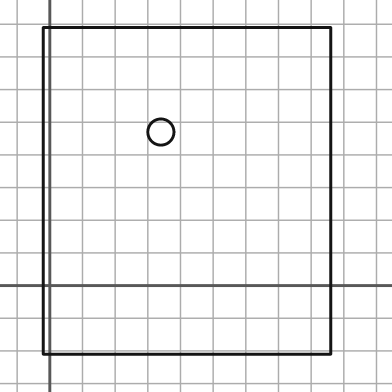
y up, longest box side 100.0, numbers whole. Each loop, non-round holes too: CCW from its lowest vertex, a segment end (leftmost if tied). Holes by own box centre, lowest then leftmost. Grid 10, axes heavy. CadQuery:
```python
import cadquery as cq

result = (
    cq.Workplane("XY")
    .moveTo(-2.0, -21.0)
    .lineTo(86.0, -21.0)
    .lineTo(86.0, 79.0)
    .lineTo(-2.0, 79.0)
    .close()
    .moveTo(34.0, 47.0)
    .circle(4.0)
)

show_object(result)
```